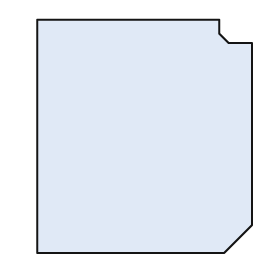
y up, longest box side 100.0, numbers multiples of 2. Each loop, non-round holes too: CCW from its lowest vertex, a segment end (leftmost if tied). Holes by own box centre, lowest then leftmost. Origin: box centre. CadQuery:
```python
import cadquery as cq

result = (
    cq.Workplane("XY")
    .moveTo(-46.0, -50.0)
    .lineTo(34.0, -50.0)
    .lineTo(46.0, -38.0)
    .lineTo(46.0, 40.0)
    .lineTo(36.0, 40.0)
    .lineTo(32.0, 44.0)
    .lineTo(32.0, 50.0)
    .lineTo(-46.0, 50.0)
    .close()
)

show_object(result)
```